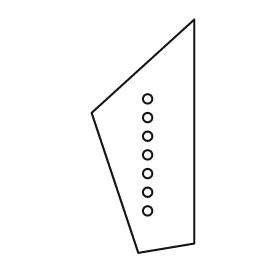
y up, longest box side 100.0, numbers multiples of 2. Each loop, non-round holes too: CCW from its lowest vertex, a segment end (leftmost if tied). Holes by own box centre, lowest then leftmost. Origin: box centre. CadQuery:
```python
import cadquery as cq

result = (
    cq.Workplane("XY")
    .moveTo(-2.0, -50.0)
    .lineTo(22.0, -46.0)
    .lineTo(22.0, 50.0)
    .lineTo(-22.0, 10.0)
    .close()
    .moveTo(2.0, -32.0)
    .circle(2.0)
    .moveTo(2.0, -24.0)
    .circle(2.0)
    .moveTo(2.0, -16.0)
    .circle(2.0)
    .moveTo(2.0, -8.0)
    .circle(2.0)
    .moveTo(2.0, 0.0)
    .circle(2.0)
    .moveTo(2.0, 8.0)
    .circle(2.0)
    .moveTo(2.0, 16.0)
    .circle(2.0)
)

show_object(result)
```